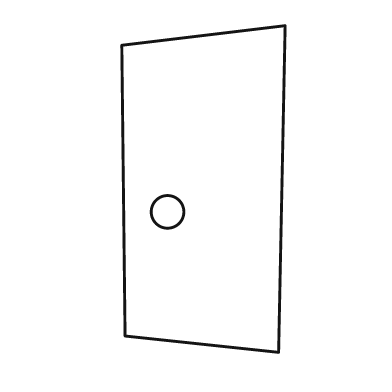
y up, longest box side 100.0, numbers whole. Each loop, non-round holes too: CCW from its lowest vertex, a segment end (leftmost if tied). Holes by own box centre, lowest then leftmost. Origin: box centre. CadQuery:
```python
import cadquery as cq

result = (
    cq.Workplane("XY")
    .moveTo(23.0, -50.0)
    .lineTo(25.0, 50.0)
    .lineTo(-25.0, 44.0)
    .lineTo(-24.0, -45.0)
    .close()
    .moveTo(-11.0, -7.0)
    .circle(5.0)
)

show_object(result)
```